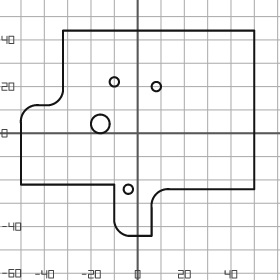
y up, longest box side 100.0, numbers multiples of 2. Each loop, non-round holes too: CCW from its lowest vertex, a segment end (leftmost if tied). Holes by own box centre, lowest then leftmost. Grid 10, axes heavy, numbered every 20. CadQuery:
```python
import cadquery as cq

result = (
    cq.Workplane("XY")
    .moveTo(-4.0, -44.0)
    .lineTo(6.0, -44.0)
    .lineTo(6.0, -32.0)
    .threePointArc((8.0, -26.0), (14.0, -24.0))
    .lineTo(50.0, -24.0)
    .lineTo(50.0, 44.0)
    .lineTo(-32.0, 44.0)
    .lineTo(-32.0, 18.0)
    .threePointArc((-34.0, 14.0), (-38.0, 12.0))
    .lineTo(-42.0, 12.0)
    .threePointArc((-48.0, 10.0), (-50.0, 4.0))
    .lineTo(-50.0, -22.0)
    .lineTo(-10.0, -22.0)
    .lineTo(-10.0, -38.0)
    .threePointArc((-8.0, -42.0), (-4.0, -44.0))
    .close()
    .moveTo(-4.0, -24.0)
    .circle(2.0)
    .moveTo(-16.0, 4.0)
    .circle(4.0)
    .moveTo(8.0, 20.0)
    .circle(2.0)
    .moveTo(-10.0, 22.0)
    .circle(2.0)
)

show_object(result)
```